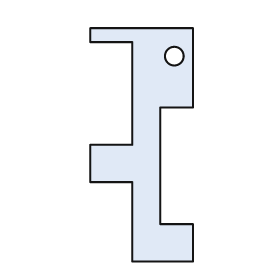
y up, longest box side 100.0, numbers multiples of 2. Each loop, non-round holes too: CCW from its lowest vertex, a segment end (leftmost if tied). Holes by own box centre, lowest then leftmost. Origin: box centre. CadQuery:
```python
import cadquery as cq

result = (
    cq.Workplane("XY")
    .moveTo(-4.0, -50.0)
    .lineTo(22.0, -50.0)
    .lineTo(22.0, -34.0)
    .lineTo(8.0, -34.0)
    .lineTo(8.0, 16.0)
    .lineTo(22.0, 16.0)
    .lineTo(22.0, 50.0)
    .lineTo(-22.0, 50.0)
    .lineTo(-22.0, 44.0)
    .lineTo(-4.0, 44.0)
    .lineTo(-4.0, 0.0)
    .lineTo(-22.0, 0.0)
    .lineTo(-22.0, -16.0)
    .lineTo(-4.0, -16.0)
    .close()
    .moveTo(14.0, 38.0)
    .circle(4.0)
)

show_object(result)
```